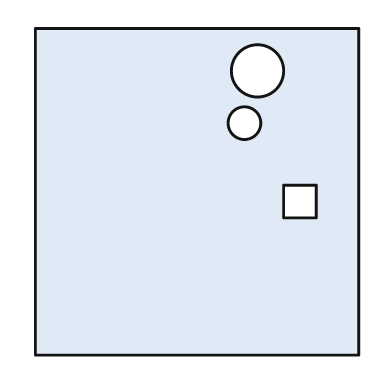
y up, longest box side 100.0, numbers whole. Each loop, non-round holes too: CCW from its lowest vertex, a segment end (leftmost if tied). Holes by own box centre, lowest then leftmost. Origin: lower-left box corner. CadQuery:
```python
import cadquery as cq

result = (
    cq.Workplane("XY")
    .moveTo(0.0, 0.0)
    .lineTo(99.0, 0.0)
    .lineTo(99.0, 100.0)
    .lineTo(0.0, 100.0)
    .close()
    .moveTo(76.0, 42.0)
    .lineTo(86.0, 42.0)
    .lineTo(86.0, 52.0)
    .lineTo(76.0, 52.0)
    .close()
    .moveTo(64.0, 71.0)
    .circle(5.0)
    .moveTo(68.0, 87.0)
    .circle(8.0)
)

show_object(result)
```